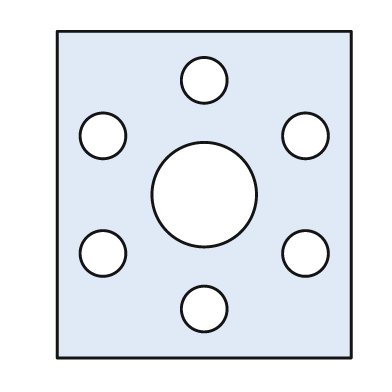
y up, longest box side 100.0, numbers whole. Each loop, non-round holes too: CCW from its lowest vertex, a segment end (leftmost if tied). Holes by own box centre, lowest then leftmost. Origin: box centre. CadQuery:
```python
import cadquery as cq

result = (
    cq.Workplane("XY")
    .moveTo(-45.0, -50.0)
    .lineTo(45.0, -50.0)
    .lineTo(45.0, 50.0)
    .lineTo(-45.0, 50.0)
    .close()
    .moveTo(0.0, -35.0)
    .circle(7.0)
    .moveTo(-31.0, -18.0)
    .circle(7.0)
    .moveTo(31.0, -18.0)
    .circle(7.0)
    .moveTo(0.0, 0.0)
    .circle(16.0)
    .moveTo(-31.0, 18.0)
    .circle(7.0)
    .moveTo(31.0, 18.0)
    .circle(7.0)
    .moveTo(0.0, 35.0)
    .circle(7.0)
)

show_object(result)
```